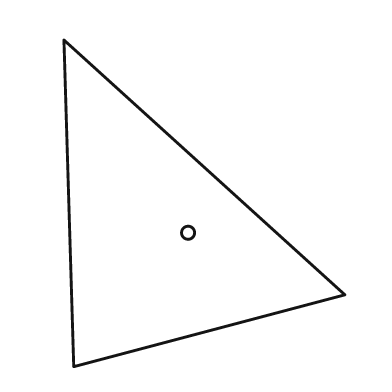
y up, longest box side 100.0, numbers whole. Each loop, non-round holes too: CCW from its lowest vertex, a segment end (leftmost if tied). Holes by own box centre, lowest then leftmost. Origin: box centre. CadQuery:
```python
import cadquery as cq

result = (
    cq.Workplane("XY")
    .moveTo(-40.0, -50.0)
    .lineTo(43.0, -28.0)
    .lineTo(-43.0, 50.0)
    .close()
    .moveTo(-5.0, -9.0)
    .circle(2.0)
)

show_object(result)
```